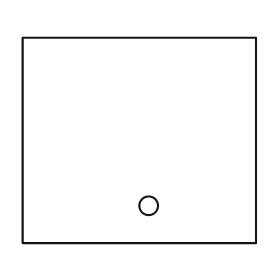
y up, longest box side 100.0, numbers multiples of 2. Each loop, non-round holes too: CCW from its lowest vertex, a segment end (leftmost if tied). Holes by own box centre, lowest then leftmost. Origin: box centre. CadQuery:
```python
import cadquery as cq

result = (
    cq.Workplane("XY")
    .moveTo(-50.0, -44.0)
    .lineTo(50.0, -44.0)
    .lineTo(50.0, 44.0)
    .lineTo(-50.0, 44.0)
    .close()
    .moveTo(4.0, -28.0)
    .circle(4.0)
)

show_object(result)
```